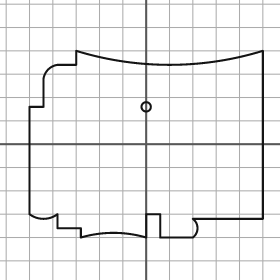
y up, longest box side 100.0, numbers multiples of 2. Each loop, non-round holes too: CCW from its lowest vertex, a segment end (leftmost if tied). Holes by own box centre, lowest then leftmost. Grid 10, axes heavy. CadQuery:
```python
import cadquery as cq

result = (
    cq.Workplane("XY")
    .moveTo(-28.0, -40.0)
    .threePointArc((-14.0, -38.0), (0.0, -40.0))
    .lineTo(0.0, -30.0)
    .lineTo(6.0, -30.0)
    .lineTo(6.0, -40.0)
    .lineTo(20.0, -40.0)
    .threePointArc((22.0, -36.0), (20.0, -32.0))
    .lineTo(50.0, -32.0)
    .lineTo(50.0, 40.0)
    .threePointArc((10.0, 34.0), (-30.0, 40.0))
    .lineTo(-30.0, 34.0)
    .lineTo(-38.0, 34.0)
    .threePointArc((-42.0, 32.0), (-44.0, 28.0))
    .lineTo(-44.0, 16.0)
    .lineTo(-50.0, 16.0)
    .lineTo(-50.0, -30.0)
    .threePointArc((-44.0, -32.0), (-38.0, -30.0))
    .lineTo(-38.0, -36.0)
    .lineTo(-28.0, -36.0)
    .close()
    .moveTo(0.0, 16.0)
    .circle(2.0)
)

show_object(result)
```